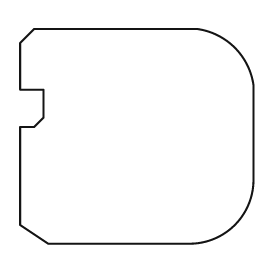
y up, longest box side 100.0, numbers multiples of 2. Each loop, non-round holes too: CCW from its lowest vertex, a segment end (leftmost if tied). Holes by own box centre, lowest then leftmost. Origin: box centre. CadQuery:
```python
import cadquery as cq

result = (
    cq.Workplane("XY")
    .moveTo(-38.0, -46.0)
    .lineTo(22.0, -46.0)
    .threePointArc((42.0, -38.0), (50.0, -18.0))
    .lineTo(50.0, 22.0)
    .threePointArc((42.0, 38.0), (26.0, 46.0))
    .lineTo(-44.0, 46.0)
    .lineTo(-50.0, 40.0)
    .lineTo(-50.0, 20.0)
    .lineTo(-40.0, 20.0)
    .lineTo(-40.0, 8.0)
    .lineTo(-44.0, 4.0)
    .lineTo(-50.0, 4.0)
    .lineTo(-50.0, -38.0)
    .close()
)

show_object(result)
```